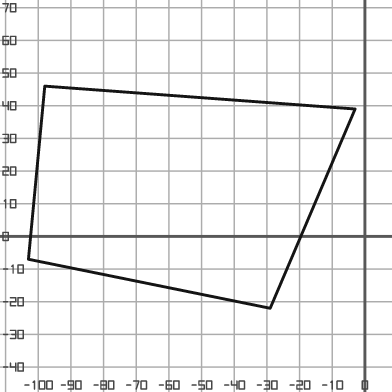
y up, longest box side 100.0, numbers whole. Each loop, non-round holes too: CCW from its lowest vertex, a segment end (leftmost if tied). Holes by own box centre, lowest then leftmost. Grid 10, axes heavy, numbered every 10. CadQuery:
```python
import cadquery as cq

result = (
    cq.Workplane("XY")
    .moveTo(-29.0, -22.0)
    .lineTo(-3.0, 39.0)
    .lineTo(-98.0, 46.0)
    .lineTo(-103.0, -7.0)
    .close()
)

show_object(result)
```